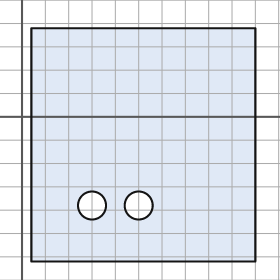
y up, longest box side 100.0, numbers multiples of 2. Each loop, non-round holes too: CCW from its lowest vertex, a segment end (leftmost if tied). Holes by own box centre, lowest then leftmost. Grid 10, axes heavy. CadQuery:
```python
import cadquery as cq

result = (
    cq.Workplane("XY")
    .moveTo(4.0, -62.0)
    .lineTo(100.0, -62.0)
    .lineTo(100.0, 38.0)
    .lineTo(4.0, 38.0)
    .close()
    .moveTo(30.0, -38.0)
    .circle(6.0)
    .moveTo(50.0, -38.0)
    .circle(6.0)
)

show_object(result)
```